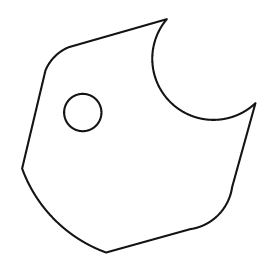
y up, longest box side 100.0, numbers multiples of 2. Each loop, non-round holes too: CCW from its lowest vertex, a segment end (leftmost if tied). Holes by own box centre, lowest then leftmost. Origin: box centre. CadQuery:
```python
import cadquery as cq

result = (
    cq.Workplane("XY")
    .moveTo(-14.0, -50.0)
    .lineTo(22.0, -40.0)
    .threePointArc((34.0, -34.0), (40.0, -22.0))
    .lineTo(50.0, 14.0)
    .threePointArc((14.0, 14.0), (12.0, 50.0))
    .lineTo(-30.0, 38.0)
    .threePointArc((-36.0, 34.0), (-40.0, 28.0))
    .lineTo(-50.0, -14.0)
    .threePointArc((-36.0, -36.0), (-14.0, -50.0))
    .close()
    .moveTo(-24.0, 10.0)
    .circle(8.0)
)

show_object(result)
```